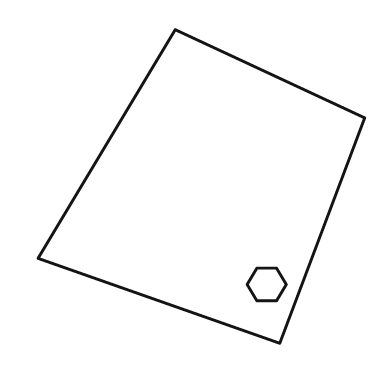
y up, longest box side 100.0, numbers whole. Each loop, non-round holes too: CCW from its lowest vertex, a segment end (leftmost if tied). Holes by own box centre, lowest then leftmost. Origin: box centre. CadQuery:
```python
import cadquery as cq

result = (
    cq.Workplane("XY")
    .moveTo(24.0, -48.0)
    .lineTo(50.0, 21.0)
    .lineTo(-8.0, 48.0)
    .lineTo(-50.0, -22.0)
    .close()
    .moveTo(17.0, -35.0)
    .lineTo(23.0, -35.0)
    .lineTo(26.0, -30.0)
    .lineTo(23.0, -25.0)
    .lineTo(17.0, -25.0)
    .lineTo(14.0, -30.0)
    .close()
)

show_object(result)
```